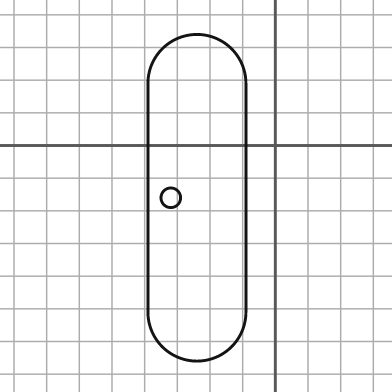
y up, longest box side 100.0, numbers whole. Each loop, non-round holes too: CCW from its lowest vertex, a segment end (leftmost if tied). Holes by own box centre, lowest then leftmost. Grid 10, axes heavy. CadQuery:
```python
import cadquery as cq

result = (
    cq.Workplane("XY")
    .moveTo(-39.0, -51.0)
    .threePointArc((-24.0, -66.0), (-9.0, -51.0))
    .lineTo(-9.0, 19.0)
    .threePointArc((-24.0, 34.0), (-39.0, 19.0))
    .close()
    .moveTo(-32.0, -16.0)
    .circle(3.0)
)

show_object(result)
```